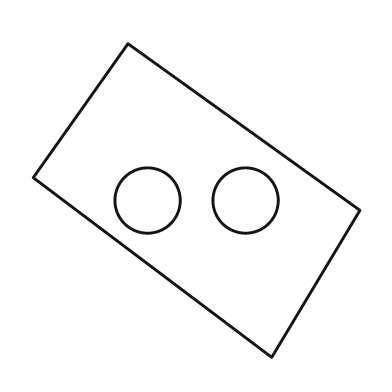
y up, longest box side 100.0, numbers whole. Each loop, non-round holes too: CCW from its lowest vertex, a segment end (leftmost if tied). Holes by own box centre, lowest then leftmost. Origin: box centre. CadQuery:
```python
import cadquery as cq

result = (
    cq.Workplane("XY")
    .moveTo(23.0, -48.0)
    .lineTo(50.0, -3.0)
    .lineTo(-21.0, 48.0)
    .lineTo(-50.0, 7.0)
    .close()
    .moveTo(-15.0, 0.0)
    .circle(10.0)
    .moveTo(15.0, 0.0)
    .circle(10.0)
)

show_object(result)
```